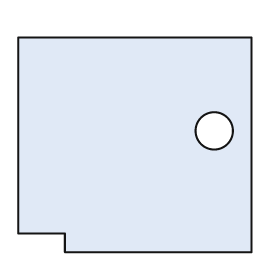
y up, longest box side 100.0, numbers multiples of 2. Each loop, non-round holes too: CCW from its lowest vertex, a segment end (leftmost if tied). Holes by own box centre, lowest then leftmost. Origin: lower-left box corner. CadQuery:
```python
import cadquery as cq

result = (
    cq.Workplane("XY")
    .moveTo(20.0, 0.0)
    .lineTo(100.0, 0.0)
    .lineTo(100.0, 92.0)
    .lineTo(0.0, 92.0)
    .lineTo(0.0, 8.0)
    .lineTo(20.0, 8.0)
    .close()
    .moveTo(84.0, 52.0)
    .circle(8.0)
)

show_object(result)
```